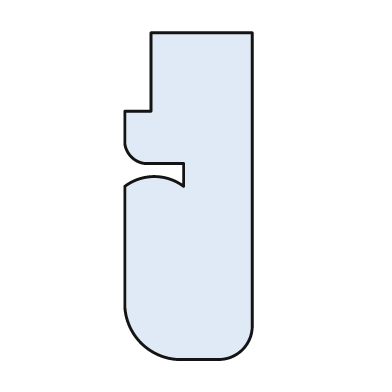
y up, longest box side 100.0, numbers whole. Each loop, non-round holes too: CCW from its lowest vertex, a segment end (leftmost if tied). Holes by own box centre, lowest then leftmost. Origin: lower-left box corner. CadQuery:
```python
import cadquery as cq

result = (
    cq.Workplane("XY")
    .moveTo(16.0, 0.0)
    .lineTo(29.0, 0.0)
    .threePointArc((36.0, 3.0), (39.0, 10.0))
    .lineTo(39.0, 100.0)
    .lineTo(8.0, 100.0)
    .lineTo(8.0, 76.0)
    .lineTo(0.0, 76.0)
    .lineTo(0.0, 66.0)
    .threePointArc((2.0, 62.0), (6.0, 60.0))
    .lineTo(18.0, 60.0)
    .lineTo(18.0, 53.0)
    .threePointArc((9.0, 56.0), (0.0, 53.0))
    .lineTo(0.0, 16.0)
    .threePointArc((5.0, 5.0), (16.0, 0.0))
    .close()
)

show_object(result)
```